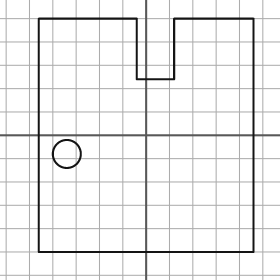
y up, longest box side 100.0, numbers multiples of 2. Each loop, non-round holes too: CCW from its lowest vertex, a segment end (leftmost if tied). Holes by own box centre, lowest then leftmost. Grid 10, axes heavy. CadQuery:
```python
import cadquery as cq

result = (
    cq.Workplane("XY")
    .moveTo(-46.0, -50.0)
    .lineTo(46.0, -50.0)
    .lineTo(46.0, 50.0)
    .lineTo(12.0, 50.0)
    .lineTo(12.0, 24.0)
    .lineTo(-4.0, 24.0)
    .lineTo(-4.0, 50.0)
    .lineTo(-46.0, 50.0)
    .close()
    .moveTo(-34.0, -8.0)
    .circle(6.0)
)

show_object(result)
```